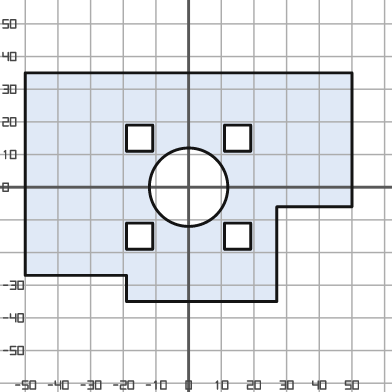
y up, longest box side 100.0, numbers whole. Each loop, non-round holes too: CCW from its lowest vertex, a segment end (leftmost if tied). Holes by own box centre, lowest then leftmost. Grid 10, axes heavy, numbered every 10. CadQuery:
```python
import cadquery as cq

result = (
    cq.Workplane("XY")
    .moveTo(-19.0, -35.0)
    .lineTo(27.0, -35.0)
    .lineTo(27.0, -6.0)
    .lineTo(50.0, -6.0)
    .lineTo(50.0, 35.0)
    .lineTo(-50.0, 35.0)
    .lineTo(-50.0, -27.0)
    .lineTo(-19.0, -27.0)
    .close()
    .moveTo(-19.0, -19.0)
    .lineTo(-11.0, -19.0)
    .lineTo(-11.0, -11.0)
    .lineTo(-19.0, -11.0)
    .close()
    .moveTo(11.0, -19.0)
    .lineTo(19.0, -19.0)
    .lineTo(19.0, -11.0)
    .lineTo(11.0, -11.0)
    .close()
    .moveTo(0.0, 0.0)
    .circle(12.0)
    .moveTo(-19.0, 11.0)
    .lineTo(-11.0, 11.0)
    .lineTo(-11.0, 19.0)
    .lineTo(-19.0, 19.0)
    .close()
    .moveTo(11.0, 11.0)
    .lineTo(19.0, 11.0)
    .lineTo(19.0, 19.0)
    .lineTo(11.0, 19.0)
    .close()
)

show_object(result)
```